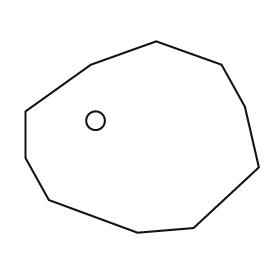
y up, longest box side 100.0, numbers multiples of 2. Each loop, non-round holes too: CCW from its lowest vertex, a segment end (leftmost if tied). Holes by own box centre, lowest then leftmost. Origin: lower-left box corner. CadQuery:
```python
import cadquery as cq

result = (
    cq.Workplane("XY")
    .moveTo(48.0, 0.0)
    .lineTo(72.0, 2.0)
    .lineTo(100.0, 28.0)
    .lineTo(94.0, 54.0)
    .lineTo(84.0, 72.0)
    .lineTo(56.0, 82.0)
    .lineTo(28.0, 72.0)
    .lineTo(0.0, 52.0)
    .lineTo(0.0, 32.0)
    .lineTo(10.0, 14.0)
    .close()
    .moveTo(30.0, 48.0)
    .circle(4.0)
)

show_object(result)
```